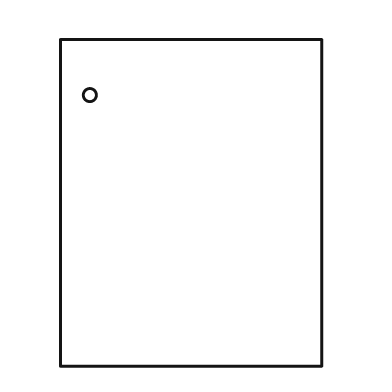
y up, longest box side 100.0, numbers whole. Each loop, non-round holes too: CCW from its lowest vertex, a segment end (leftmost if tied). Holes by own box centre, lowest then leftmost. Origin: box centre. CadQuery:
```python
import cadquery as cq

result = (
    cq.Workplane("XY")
    .moveTo(-40.0, -50.0)
    .lineTo(40.0, -50.0)
    .lineTo(40.0, 50.0)
    .lineTo(-40.0, 50.0)
    .close()
    .moveTo(-31.0, 33.0)
    .circle(2.0)
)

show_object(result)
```